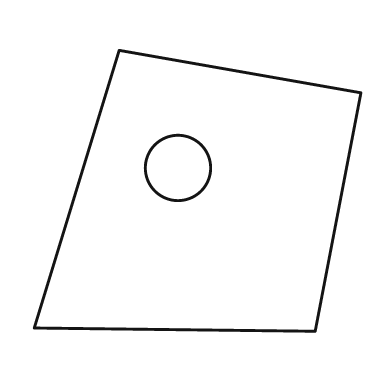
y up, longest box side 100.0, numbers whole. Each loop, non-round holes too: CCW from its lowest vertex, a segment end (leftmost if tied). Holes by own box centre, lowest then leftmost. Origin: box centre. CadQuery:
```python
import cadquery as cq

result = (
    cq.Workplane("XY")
    .moveTo(36.0, -43.0)
    .lineTo(50.0, 30.0)
    .lineTo(-24.0, 43.0)
    .lineTo(-50.0, -42.0)
    .close()
    .moveTo(-6.0, 7.0)
    .circle(10.0)
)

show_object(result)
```